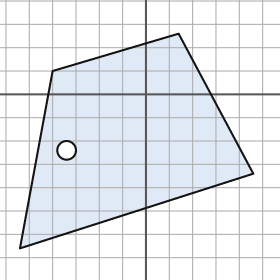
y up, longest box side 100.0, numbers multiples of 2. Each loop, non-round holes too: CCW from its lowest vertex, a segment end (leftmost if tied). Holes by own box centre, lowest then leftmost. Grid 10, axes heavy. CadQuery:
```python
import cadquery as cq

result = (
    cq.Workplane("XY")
    .moveTo(-54.0, -66.0)
    .lineTo(46.0, -34.0)
    .lineTo(14.0, 26.0)
    .lineTo(-40.0, 10.0)
    .close()
    .moveTo(-34.0, -24.0)
    .circle(4.0)
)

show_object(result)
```